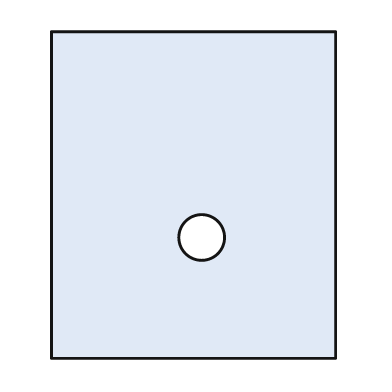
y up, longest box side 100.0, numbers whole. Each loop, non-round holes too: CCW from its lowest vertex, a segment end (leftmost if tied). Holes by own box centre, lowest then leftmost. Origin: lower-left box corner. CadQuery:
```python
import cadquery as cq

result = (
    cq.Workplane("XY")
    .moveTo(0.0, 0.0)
    .lineTo(87.0, 0.0)
    .lineTo(87.0, 100.0)
    .lineTo(0.0, 100.0)
    .close()
    .moveTo(46.0, 37.0)
    .circle(7.0)
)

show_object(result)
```